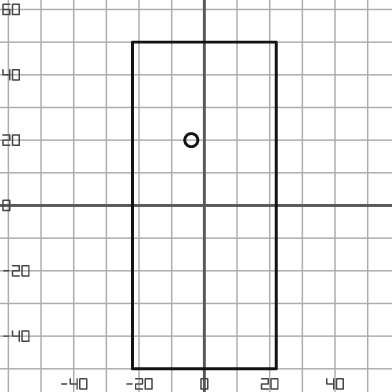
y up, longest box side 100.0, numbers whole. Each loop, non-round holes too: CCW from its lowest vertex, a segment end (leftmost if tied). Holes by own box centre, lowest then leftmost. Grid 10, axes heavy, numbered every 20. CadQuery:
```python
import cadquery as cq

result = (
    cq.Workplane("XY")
    .moveTo(-22.0, -50.0)
    .lineTo(22.0, -50.0)
    .lineTo(22.0, 50.0)
    .lineTo(-22.0, 50.0)
    .close()
    .moveTo(-4.0, 20.0)
    .circle(2.0)
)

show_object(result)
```